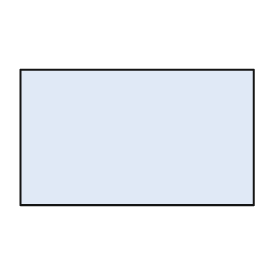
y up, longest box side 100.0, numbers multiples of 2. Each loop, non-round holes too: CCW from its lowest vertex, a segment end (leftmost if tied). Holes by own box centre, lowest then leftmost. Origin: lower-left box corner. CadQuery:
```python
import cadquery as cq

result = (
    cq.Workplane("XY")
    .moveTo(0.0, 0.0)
    .lineTo(100.0, 0.0)
    .lineTo(100.0, 58.0)
    .lineTo(0.0, 58.0)
    .close()
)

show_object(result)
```